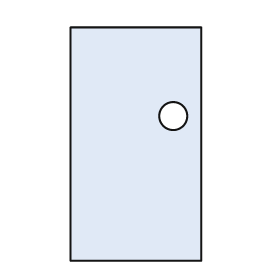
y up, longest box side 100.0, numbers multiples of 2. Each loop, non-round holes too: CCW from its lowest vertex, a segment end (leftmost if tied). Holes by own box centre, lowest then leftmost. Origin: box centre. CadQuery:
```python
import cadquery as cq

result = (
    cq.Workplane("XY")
    .moveTo(-28.0, -50.0)
    .lineTo(28.0, -50.0)
    .lineTo(28.0, 50.0)
    .lineTo(-28.0, 50.0)
    .close()
    .moveTo(16.0, 12.0)
    .circle(6.0)
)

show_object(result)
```